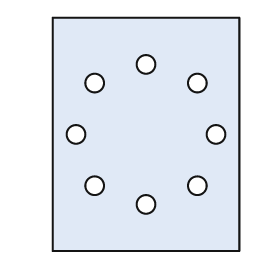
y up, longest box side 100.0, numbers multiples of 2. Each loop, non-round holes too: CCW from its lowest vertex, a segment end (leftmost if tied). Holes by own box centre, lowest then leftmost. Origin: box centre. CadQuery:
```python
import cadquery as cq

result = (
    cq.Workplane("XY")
    .moveTo(-40.0, -50.0)
    .lineTo(40.0, -50.0)
    .lineTo(40.0, 50.0)
    .lineTo(-40.0, 50.0)
    .close()
    .moveTo(0.0, -30.0)
    .circle(4.0)
    .moveTo(-22.0, -22.0)
    .circle(4.0)
    .moveTo(22.0, -22.0)
    .circle(4.0)
    .moveTo(-30.0, 0.0)
    .circle(4.0)
    .moveTo(30.0, 0.0)
    .circle(4.0)
    .moveTo(-22.0, 22.0)
    .circle(4.0)
    .moveTo(22.0, 22.0)
    .circle(4.0)
    .moveTo(0.0, 30.0)
    .circle(4.0)
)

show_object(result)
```